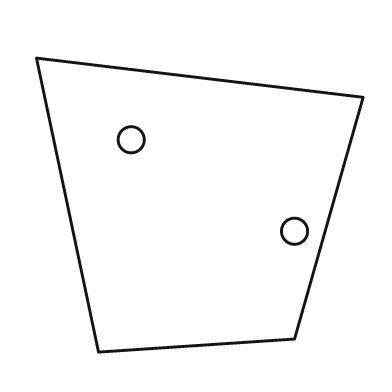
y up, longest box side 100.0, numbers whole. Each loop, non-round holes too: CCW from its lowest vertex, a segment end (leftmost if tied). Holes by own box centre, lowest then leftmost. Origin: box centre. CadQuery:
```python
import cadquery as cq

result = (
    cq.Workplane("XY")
    .moveTo(-31.0, -45.0)
    .lineTo(29.0, -41.0)
    .lineTo(50.0, 33.0)
    .lineTo(-50.0, 45.0)
    .close()
    .moveTo(29.0, -8.0)
    .circle(4.0)
    .moveTo(-21.0, 20.0)
    .circle(4.0)
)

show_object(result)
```